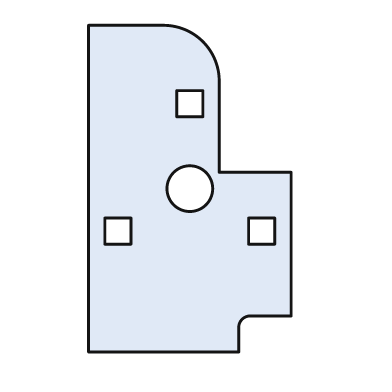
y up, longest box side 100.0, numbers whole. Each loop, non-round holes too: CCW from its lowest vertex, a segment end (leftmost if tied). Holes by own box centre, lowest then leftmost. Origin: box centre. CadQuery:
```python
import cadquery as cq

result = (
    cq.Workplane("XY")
    .moveTo(-31.0, -50.0)
    .lineTo(15.0, -50.0)
    .lineTo(15.0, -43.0)
    .threePointArc((16.0, -40.0), (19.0, -39.0))
    .lineTo(31.0, -39.0)
    .lineTo(31.0, 5.0)
    .lineTo(9.0, 5.0)
    .lineTo(9.0, 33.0)
    .threePointArc((4.0, 45.0), (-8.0, 50.0))
    .lineTo(-31.0, 50.0)
    .close()
    .moveTo(-26.0, -17.0)
    .lineTo(-18.0, -17.0)
    .lineTo(-18.0, -9.0)
    .lineTo(-26.0, -9.0)
    .close()
    .moveTo(18.0, -17.0)
    .lineTo(26.0, -17.0)
    .lineTo(26.0, -9.0)
    .lineTo(18.0, -9.0)
    .close()
    .moveTo(0.0, 0.0)
    .circle(7.0)
    .moveTo(-4.0, 22.0)
    .lineTo(4.0, 22.0)
    .lineTo(4.0, 30.0)
    .lineTo(-4.0, 30.0)
    .close()
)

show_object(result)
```